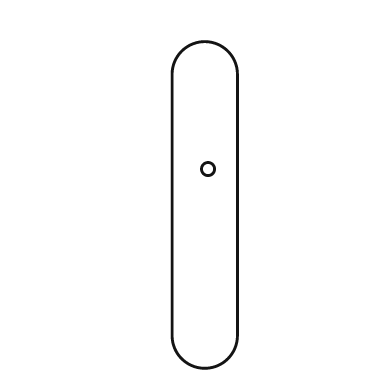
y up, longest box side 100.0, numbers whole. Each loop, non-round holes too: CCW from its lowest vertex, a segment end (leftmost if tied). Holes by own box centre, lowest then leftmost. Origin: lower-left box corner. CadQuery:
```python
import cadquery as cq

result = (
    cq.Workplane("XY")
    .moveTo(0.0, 10.0)
    .threePointArc((10.0, 0.0), (20.0, 10.0))
    .lineTo(20.0, 90.0)
    .threePointArc((10.0, 100.0), (0.0, 90.0))
    .close()
    .moveTo(11.0, 61.0)
    .circle(2.0)
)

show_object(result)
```